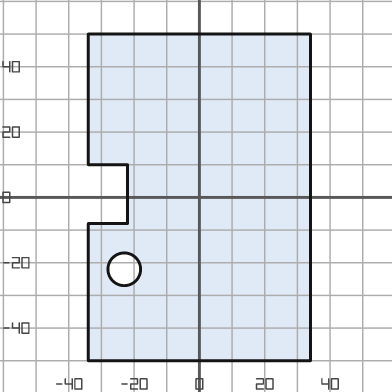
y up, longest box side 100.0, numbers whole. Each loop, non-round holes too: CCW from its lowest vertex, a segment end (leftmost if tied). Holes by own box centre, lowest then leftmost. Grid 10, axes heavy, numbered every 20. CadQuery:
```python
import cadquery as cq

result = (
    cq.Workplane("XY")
    .moveTo(-34.0, -50.0)
    .lineTo(34.0, -50.0)
    .lineTo(34.0, 50.0)
    .lineTo(-34.0, 50.0)
    .lineTo(-34.0, 10.0)
    .lineTo(-22.0, 10.0)
    .lineTo(-22.0, -8.0)
    .lineTo(-34.0, -8.0)
    .close()
    .moveTo(-23.0, -22.0)
    .circle(5.0)
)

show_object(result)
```